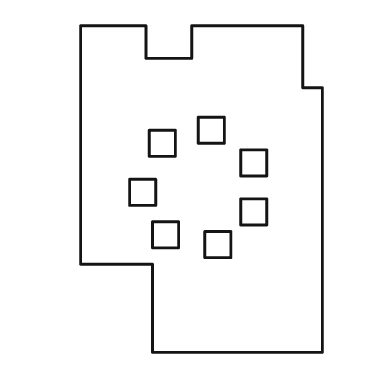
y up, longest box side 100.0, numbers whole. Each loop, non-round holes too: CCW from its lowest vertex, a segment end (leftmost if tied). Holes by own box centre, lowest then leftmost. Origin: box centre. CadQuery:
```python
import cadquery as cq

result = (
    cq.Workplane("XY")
    .moveTo(-15.0, -50.0)
    .lineTo(37.0, -50.0)
    .lineTo(37.0, 31.0)
    .lineTo(31.0, 31.0)
    .lineTo(31.0, 50.0)
    .lineTo(-3.0, 50.0)
    .lineTo(-3.0, 40.0)
    .lineTo(-17.0, 40.0)
    .lineTo(-17.0, 50.0)
    .lineTo(-37.0, 50.0)
    .lineTo(-37.0, -23.0)
    .lineTo(-15.0, -23.0)
    .close()
    .moveTo(1.0, -21.0)
    .lineTo(9.0, -21.0)
    .lineTo(9.0, -13.0)
    .lineTo(1.0, -13.0)
    .close()
    .moveTo(-15.0, -18.0)
    .lineTo(-7.0, -18.0)
    .lineTo(-7.0, -10.0)
    .lineTo(-15.0, -10.0)
    .close()
    .moveTo(12.0, -11.0)
    .lineTo(20.0, -11.0)
    .lineTo(20.0, -3.0)
    .lineTo(12.0, -3.0)
    .close()
    .moveTo(-22.0, -5.0)
    .lineTo(-14.0, -5.0)
    .lineTo(-14.0, 3.0)
    .lineTo(-22.0, 3.0)
    .close()
    .moveTo(12.0, 4.0)
    .lineTo(20.0, 4.0)
    .lineTo(20.0, 12.0)
    .lineTo(12.0, 12.0)
    .close()
    .moveTo(-16.0, 10.0)
    .lineTo(-8.0, 10.0)
    .lineTo(-8.0, 18.0)
    .lineTo(-16.0, 18.0)
    .close()
    .moveTo(-1.0, 14.0)
    .lineTo(7.0, 14.0)
    .lineTo(7.0, 22.0)
    .lineTo(-1.0, 22.0)
    .close()
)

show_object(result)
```